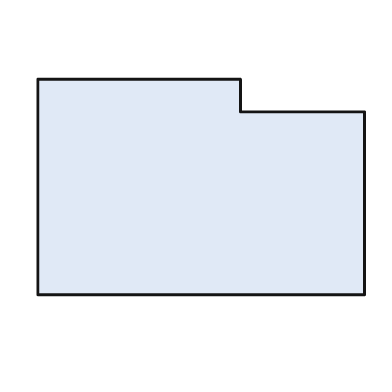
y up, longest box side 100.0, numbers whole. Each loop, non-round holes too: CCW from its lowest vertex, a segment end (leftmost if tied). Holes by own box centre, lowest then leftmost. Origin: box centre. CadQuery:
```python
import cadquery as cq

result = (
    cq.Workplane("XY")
    .moveTo(-50.0, -33.0)
    .lineTo(50.0, -33.0)
    .lineTo(50.0, 23.0)
    .lineTo(12.0, 23.0)
    .lineTo(12.0, 33.0)
    .lineTo(-50.0, 33.0)
    .close()
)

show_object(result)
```